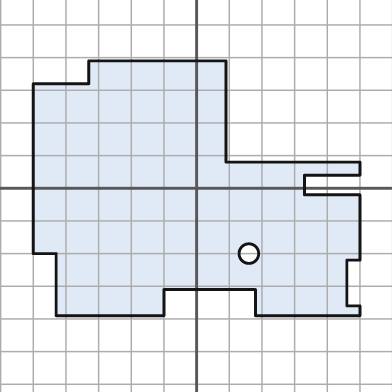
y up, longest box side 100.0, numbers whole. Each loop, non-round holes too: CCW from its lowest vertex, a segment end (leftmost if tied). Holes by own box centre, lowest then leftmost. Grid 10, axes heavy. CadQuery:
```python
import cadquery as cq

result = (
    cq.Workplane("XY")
    .moveTo(-43.0, -39.0)
    .lineTo(-10.0, -39.0)
    .lineTo(-10.0, -31.0)
    .lineTo(18.0, -31.0)
    .lineTo(18.0, -39.0)
    .lineTo(50.0, -39.0)
    .lineTo(50.0, -36.0)
    .lineTo(46.0, -36.0)
    .lineTo(46.0, -22.0)
    .lineTo(50.0, -22.0)
    .lineTo(50.0, -2.0)
    .lineTo(33.0, -2.0)
    .lineTo(33.0, 4.0)
    .lineTo(50.0, 4.0)
    .lineTo(50.0, 8.0)
    .lineTo(9.0, 8.0)
    .lineTo(9.0, 39.0)
    .lineTo(-33.0, 39.0)
    .lineTo(-33.0, 32.0)
    .lineTo(-50.0, 32.0)
    .lineTo(-50.0, -20.0)
    .lineTo(-43.0, -20.0)
    .close()
    .moveTo(16.0, -20.0)
    .circle(3.0)
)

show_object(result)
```